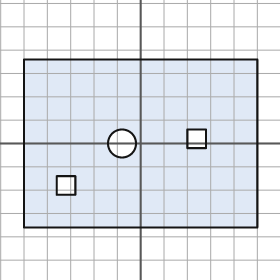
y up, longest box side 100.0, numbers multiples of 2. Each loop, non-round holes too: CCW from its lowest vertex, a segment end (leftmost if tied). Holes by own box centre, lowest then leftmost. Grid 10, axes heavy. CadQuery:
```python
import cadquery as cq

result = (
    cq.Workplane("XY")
    .moveTo(-50.0, -36.0)
    .lineTo(50.0, -36.0)
    .lineTo(50.0, 36.0)
    .lineTo(-50.0, 36.0)
    .close()
    .moveTo(-36.0, -22.0)
    .lineTo(-28.0, -22.0)
    .lineTo(-28.0, -14.0)
    .lineTo(-36.0, -14.0)
    .close()
    .moveTo(-8.0, 0.0)
    .circle(6.0)
    .moveTo(20.0, -2.0)
    .lineTo(28.0, -2.0)
    .lineTo(28.0, 6.0)
    .lineTo(20.0, 6.0)
    .close()
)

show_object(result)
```